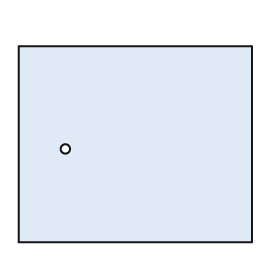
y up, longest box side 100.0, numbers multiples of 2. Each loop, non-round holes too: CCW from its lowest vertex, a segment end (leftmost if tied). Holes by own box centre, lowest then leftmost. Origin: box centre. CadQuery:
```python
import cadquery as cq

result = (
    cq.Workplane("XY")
    .moveTo(-50.0, -42.0)
    .lineTo(50.0, -42.0)
    .lineTo(50.0, 42.0)
    .lineTo(-50.0, 42.0)
    .close()
    .moveTo(-30.0, -2.0)
    .circle(2.0)
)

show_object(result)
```